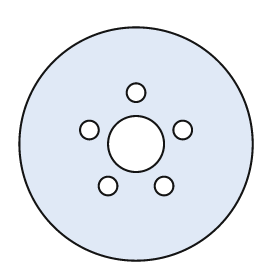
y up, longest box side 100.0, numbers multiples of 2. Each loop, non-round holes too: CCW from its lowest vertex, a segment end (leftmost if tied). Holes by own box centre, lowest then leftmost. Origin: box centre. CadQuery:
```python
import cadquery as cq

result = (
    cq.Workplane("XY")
    .moveTo(0.0, 0.0)
    .circle(50.0)
    .moveTo(-12.0, -18.0)
    .circle(4.0)
    .moveTo(12.0, -18.0)
    .circle(4.0)
    .moveTo(0.0, 0.0)
    .circle(12.0)
    .moveTo(-20.0, 6.0)
    .circle(4.0)
    .moveTo(20.0, 6.0)
    .circle(4.0)
    .moveTo(0.0, 22.0)
    .circle(4.0)
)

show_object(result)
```